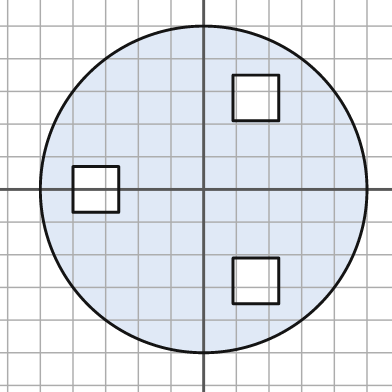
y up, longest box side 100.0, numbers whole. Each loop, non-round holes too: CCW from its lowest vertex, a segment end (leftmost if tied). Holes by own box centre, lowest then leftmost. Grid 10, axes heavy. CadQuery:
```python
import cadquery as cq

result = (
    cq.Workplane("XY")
    .moveTo(0.0, 0.0)
    .circle(50.0)
    .moveTo(9.0, -35.0)
    .lineTo(23.0, -35.0)
    .lineTo(23.0, -21.0)
    .lineTo(9.0, -21.0)
    .close()
    .moveTo(-40.0, -7.0)
    .lineTo(-26.0, -7.0)
    .lineTo(-26.0, 7.0)
    .lineTo(-40.0, 7.0)
    .close()
    .moveTo(9.0, 21.0)
    .lineTo(23.0, 21.0)
    .lineTo(23.0, 35.0)
    .lineTo(9.0, 35.0)
    .close()
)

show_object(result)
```